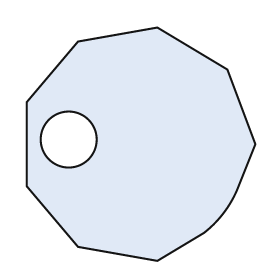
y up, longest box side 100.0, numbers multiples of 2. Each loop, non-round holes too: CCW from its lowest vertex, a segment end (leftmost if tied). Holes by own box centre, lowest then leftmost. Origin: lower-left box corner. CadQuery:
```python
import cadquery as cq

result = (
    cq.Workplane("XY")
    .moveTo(56.0, 0.0)
    .lineTo(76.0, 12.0)
    .threePointArc((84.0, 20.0), (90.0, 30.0))
    .lineTo(98.0, 50.0)
    .lineTo(86.0, 82.0)
    .lineTo(56.0, 100.0)
    .lineTo(22.0, 94.0)
    .lineTo(0.0, 68.0)
    .lineTo(0.0, 32.0)
    .lineTo(22.0, 6.0)
    .close()
    .moveTo(18.0, 52.0)
    .circle(12.0)
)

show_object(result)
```